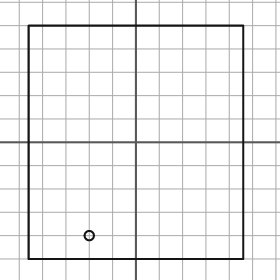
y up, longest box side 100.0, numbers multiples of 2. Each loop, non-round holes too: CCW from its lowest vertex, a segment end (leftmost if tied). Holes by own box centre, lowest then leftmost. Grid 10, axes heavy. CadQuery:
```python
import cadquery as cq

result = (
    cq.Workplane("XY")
    .moveTo(-46.0, -50.0)
    .lineTo(46.0, -50.0)
    .lineTo(46.0, 50.0)
    .lineTo(-46.0, 50.0)
    .close()
    .moveTo(-20.0, -40.0)
    .circle(2.0)
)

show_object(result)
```